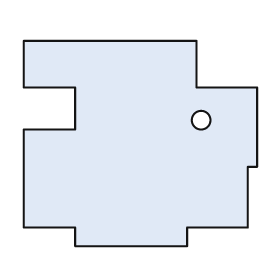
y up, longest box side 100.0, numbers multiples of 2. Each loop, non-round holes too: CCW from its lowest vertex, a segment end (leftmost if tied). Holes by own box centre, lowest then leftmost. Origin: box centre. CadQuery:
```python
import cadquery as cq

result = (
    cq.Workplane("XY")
    .moveTo(-28.0, -44.0)
    .lineTo(20.0, -44.0)
    .lineTo(20.0, -36.0)
    .lineTo(46.0, -36.0)
    .lineTo(46.0, -10.0)
    .lineTo(50.0, -10.0)
    .lineTo(50.0, 24.0)
    .lineTo(24.0, 24.0)
    .lineTo(24.0, 44.0)
    .lineTo(-50.0, 44.0)
    .lineTo(-50.0, 24.0)
    .lineTo(-28.0, 24.0)
    .lineTo(-28.0, 6.0)
    .lineTo(-50.0, 6.0)
    .lineTo(-50.0, -36.0)
    .lineTo(-28.0, -36.0)
    .close()
    .moveTo(26.0, 10.0)
    .circle(4.0)
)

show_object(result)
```